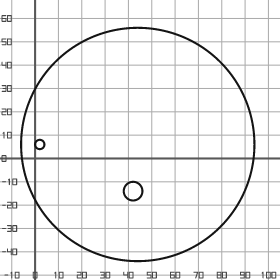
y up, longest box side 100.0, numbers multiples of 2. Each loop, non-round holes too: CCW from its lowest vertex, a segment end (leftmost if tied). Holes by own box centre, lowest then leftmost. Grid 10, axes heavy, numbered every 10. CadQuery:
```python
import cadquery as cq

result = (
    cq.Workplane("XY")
    .moveTo(44.0, 6.0)
    .circle(50.0)
    .moveTo(42.0, -14.0)
    .circle(4.0)
    .moveTo(2.0, 6.0)
    .circle(2.0)
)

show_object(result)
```